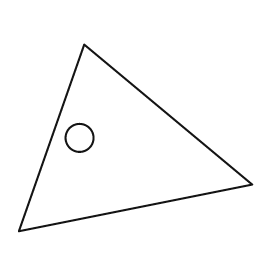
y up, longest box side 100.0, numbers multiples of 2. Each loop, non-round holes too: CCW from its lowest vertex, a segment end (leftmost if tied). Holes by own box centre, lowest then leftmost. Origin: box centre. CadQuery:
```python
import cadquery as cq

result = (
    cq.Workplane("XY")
    .moveTo(-50.0, -40.0)
    .lineTo(50.0, -20.0)
    .lineTo(-22.0, 40.0)
    .close()
    .moveTo(-24.0, 0.0)
    .circle(6.0)
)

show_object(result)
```